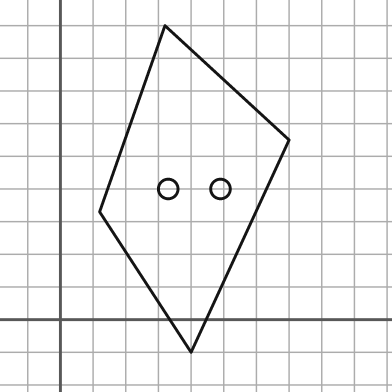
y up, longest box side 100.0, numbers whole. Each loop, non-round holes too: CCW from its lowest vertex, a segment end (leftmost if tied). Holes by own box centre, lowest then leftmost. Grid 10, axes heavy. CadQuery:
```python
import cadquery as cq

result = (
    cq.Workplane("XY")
    .moveTo(40.0, -10.0)
    .lineTo(70.0, 55.0)
    .lineTo(32.0, 90.0)
    .lineTo(12.0, 33.0)
    .close()
    .moveTo(33.0, 40.0)
    .circle(3.0)
    .moveTo(49.0, 40.0)
    .circle(3.0)
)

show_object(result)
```